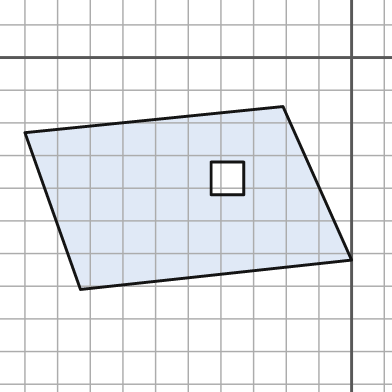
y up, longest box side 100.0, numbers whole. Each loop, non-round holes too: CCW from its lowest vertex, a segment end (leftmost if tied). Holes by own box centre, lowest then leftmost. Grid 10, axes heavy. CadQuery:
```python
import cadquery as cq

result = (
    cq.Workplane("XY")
    .moveTo(-83.0, -71.0)
    .lineTo(0.0, -62.0)
    .lineTo(-21.0, -15.0)
    .lineTo(-100.0, -23.0)
    .close()
    .moveTo(-43.0, -42.0)
    .lineTo(-33.0, -42.0)
    .lineTo(-33.0, -32.0)
    .lineTo(-43.0, -32.0)
    .close()
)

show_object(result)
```